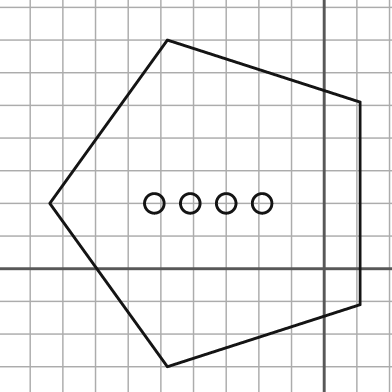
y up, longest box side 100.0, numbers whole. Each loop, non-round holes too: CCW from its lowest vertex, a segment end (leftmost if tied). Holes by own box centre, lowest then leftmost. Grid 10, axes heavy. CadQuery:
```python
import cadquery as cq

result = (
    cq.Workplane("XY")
    .moveTo(-48.0, -30.0)
    .lineTo(11.0, -11.0)
    .lineTo(11.0, 51.0)
    .lineTo(-48.0, 70.0)
    .lineTo(-84.0, 20.0)
    .close()
    .moveTo(-52.0, 20.0)
    .circle(3.0)
    .moveTo(-41.0, 20.0)
    .circle(3.0)
    .moveTo(-30.0, 20.0)
    .circle(3.0)
    .moveTo(-19.0, 20.0)
    .circle(3.0)
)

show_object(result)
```